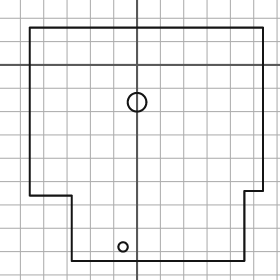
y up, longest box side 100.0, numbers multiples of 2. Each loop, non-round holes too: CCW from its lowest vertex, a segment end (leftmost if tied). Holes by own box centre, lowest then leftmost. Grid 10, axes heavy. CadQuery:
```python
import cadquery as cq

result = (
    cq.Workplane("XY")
    .moveTo(-28.0, -84.0)
    .lineTo(46.0, -84.0)
    .lineTo(46.0, -54.0)
    .lineTo(54.0, -54.0)
    .lineTo(54.0, 16.0)
    .lineTo(-46.0, 16.0)
    .lineTo(-46.0, -56.0)
    .lineTo(-28.0, -56.0)
    .close()
    .moveTo(-6.0, -78.0)
    .circle(2.0)
    .moveTo(0.0, -16.0)
    .circle(4.0)
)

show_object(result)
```